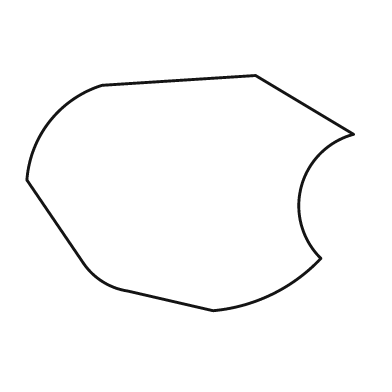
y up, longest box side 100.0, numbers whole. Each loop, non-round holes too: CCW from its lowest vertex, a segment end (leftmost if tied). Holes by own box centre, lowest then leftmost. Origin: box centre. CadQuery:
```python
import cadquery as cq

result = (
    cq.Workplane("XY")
    .moveTo(7.0, -36.0)
    .threePointArc((25.0, -31.0), (40.0, -20.0))
    .threePointArc((34.0, 2.0), (50.0, 18.0))
    .lineTo(20.0, 36.0)
    .lineTo(-27.0, 33.0)
    .threePointArc((-43.0, 22.0), (-50.0, 4.0))
    .lineTo(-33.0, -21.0)
    .threePointArc((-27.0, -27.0), (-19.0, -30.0))
    .close()
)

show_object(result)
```